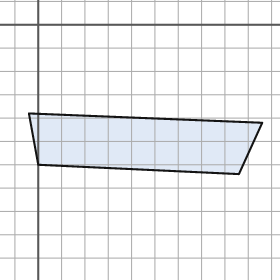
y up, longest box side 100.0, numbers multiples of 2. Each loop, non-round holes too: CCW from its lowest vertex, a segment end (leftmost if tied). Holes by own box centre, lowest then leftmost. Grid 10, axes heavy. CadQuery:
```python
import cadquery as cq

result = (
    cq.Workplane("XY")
    .moveTo(86.0, -64.0)
    .lineTo(96.0, -42.0)
    .lineTo(-4.0, -38.0)
    .lineTo(0.0, -60.0)
    .close()
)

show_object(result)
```